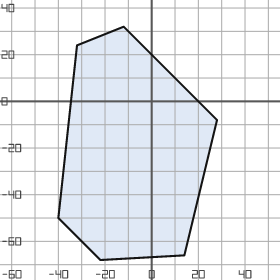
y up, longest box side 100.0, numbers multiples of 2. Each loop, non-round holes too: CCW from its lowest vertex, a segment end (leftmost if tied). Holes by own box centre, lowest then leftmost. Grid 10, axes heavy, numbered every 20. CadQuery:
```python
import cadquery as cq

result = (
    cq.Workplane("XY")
    .moveTo(-22.0, -68.0)
    .lineTo(14.0, -66.0)
    .lineTo(28.0, -8.0)
    .lineTo(-12.0, 32.0)
    .lineTo(-32.0, 24.0)
    .lineTo(-40.0, -50.0)
    .close()
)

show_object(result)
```